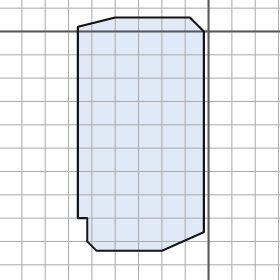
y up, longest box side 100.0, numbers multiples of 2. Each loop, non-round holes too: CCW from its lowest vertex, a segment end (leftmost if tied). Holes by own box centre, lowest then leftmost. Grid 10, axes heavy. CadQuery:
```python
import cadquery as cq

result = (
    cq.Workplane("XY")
    .moveTo(-48.0, -94.0)
    .lineTo(-20.0, -94.0)
    .lineTo(-2.0, -86.0)
    .lineTo(-2.0, 0.0)
    .lineTo(-8.0, 6.0)
    .lineTo(-40.0, 6.0)
    .lineTo(-56.0, 2.0)
    .lineTo(-56.0, -80.0)
    .lineTo(-52.0, -80.0)
    .lineTo(-52.0, -90.0)
    .close()
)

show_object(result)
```